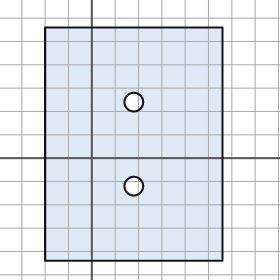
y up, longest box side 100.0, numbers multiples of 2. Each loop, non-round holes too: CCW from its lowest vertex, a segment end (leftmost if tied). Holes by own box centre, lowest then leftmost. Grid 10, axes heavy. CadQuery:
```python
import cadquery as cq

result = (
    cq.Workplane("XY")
    .moveTo(-20.0, -44.0)
    .lineTo(56.0, -44.0)
    .lineTo(56.0, 56.0)
    .lineTo(-20.0, 56.0)
    .close()
    .moveTo(18.0, -12.0)
    .circle(4.0)
    .moveTo(18.0, 24.0)
    .circle(4.0)
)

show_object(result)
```